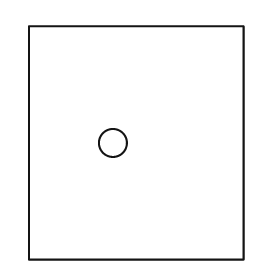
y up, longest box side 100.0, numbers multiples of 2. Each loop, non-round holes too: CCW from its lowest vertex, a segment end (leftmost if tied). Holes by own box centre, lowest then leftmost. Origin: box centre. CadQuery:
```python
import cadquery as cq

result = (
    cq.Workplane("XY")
    .moveTo(-46.0, -50.0)
    .lineTo(46.0, -50.0)
    .lineTo(46.0, 50.0)
    .lineTo(-46.0, 50.0)
    .close()
    .moveTo(-10.0, 0.0)
    .circle(6.0)
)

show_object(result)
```